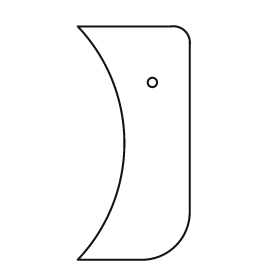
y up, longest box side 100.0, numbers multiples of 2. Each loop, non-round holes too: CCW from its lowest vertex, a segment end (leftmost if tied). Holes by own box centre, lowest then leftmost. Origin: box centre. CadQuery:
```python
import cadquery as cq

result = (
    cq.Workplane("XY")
    .moveTo(-24.0, -50.0)
    .lineTo(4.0, -50.0)
    .threePointArc((18.0, -44.0), (24.0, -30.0))
    .lineTo(24.0, 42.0)
    .threePointArc((22.0, 48.0), (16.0, 50.0))
    .lineTo(-24.0, 50.0)
    .threePointArc((-4.0, 0.0), (-24.0, -50.0))
    .close()
    .moveTo(8.0, 26.0)
    .circle(2.0)
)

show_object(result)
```